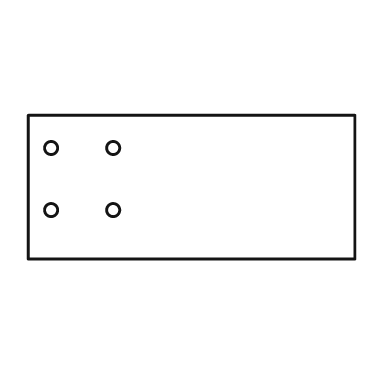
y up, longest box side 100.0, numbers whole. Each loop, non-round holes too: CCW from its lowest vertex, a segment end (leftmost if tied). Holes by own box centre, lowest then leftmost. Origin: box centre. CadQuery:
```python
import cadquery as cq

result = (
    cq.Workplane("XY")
    .moveTo(-50.0, -22.0)
    .lineTo(50.0, -22.0)
    .lineTo(50.0, 22.0)
    .lineTo(-50.0, 22.0)
    .close()
    .moveTo(-43.0, -7.0)
    .circle(2.0)
    .moveTo(-24.0, -7.0)
    .circle(2.0)
    .moveTo(-43.0, 12.0)
    .circle(2.0)
    .moveTo(-24.0, 12.0)
    .circle(2.0)
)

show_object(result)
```